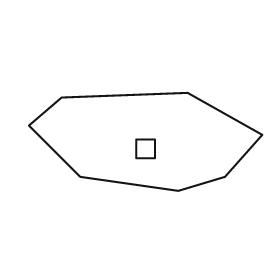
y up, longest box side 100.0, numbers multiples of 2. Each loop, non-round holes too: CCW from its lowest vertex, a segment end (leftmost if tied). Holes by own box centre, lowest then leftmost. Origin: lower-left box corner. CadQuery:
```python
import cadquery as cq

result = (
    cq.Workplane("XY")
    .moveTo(64.0, 0.0)
    .lineTo(84.0, 6.0)
    .lineTo(100.0, 24.0)
    .lineTo(68.0, 42.0)
    .lineTo(14.0, 40.0)
    .lineTo(0.0, 28.0)
    .lineTo(22.0, 6.0)
    .close()
    .moveTo(46.0, 14.0)
    .lineTo(54.0, 14.0)
    .lineTo(54.0, 22.0)
    .lineTo(46.0, 22.0)
    .close()
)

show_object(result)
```